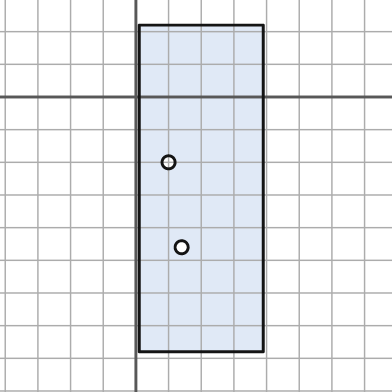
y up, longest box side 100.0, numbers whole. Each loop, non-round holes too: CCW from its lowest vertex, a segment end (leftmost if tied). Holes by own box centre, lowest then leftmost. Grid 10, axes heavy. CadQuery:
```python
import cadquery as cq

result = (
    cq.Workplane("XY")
    .moveTo(1.0, -78.0)
    .lineTo(39.0, -78.0)
    .lineTo(39.0, 22.0)
    .lineTo(1.0, 22.0)
    .close()
    .moveTo(14.0, -46.0)
    .circle(2.0)
    .moveTo(10.0, -20.0)
    .circle(2.0)
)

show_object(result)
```